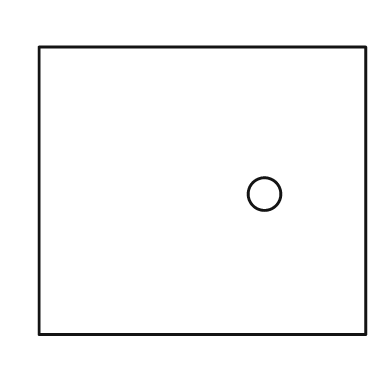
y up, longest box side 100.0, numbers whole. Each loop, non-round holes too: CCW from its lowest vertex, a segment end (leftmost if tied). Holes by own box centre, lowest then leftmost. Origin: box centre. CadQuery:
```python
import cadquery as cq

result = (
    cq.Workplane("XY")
    .moveTo(-50.0, -44.0)
    .lineTo(50.0, -44.0)
    .lineTo(50.0, 44.0)
    .lineTo(-50.0, 44.0)
    .close()
    .moveTo(19.0, -1.0)
    .circle(5.0)
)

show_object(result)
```